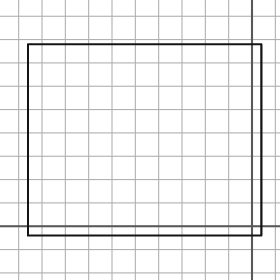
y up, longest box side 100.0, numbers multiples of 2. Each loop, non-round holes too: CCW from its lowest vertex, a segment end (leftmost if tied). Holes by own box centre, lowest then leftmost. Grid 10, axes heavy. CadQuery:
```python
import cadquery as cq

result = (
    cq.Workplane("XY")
    .moveTo(-96.0, -4.0)
    .lineTo(4.0, -4.0)
    .lineTo(4.0, 78.0)
    .lineTo(-96.0, 78.0)
    .close()
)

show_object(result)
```